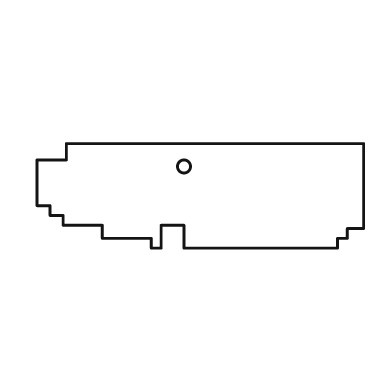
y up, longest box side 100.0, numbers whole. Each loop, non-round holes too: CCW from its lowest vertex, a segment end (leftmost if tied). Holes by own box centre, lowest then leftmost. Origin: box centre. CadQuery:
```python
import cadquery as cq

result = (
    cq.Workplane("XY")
    .moveTo(-15.0, -16.0)
    .lineTo(-12.0, -16.0)
    .lineTo(-12.0, -9.0)
    .lineTo(-5.0, -9.0)
    .lineTo(-5.0, -16.0)
    .lineTo(42.0, -16.0)
    .lineTo(42.0, -13.0)
    .lineTo(45.0, -13.0)
    .lineTo(45.0, -10.0)
    .lineTo(50.0, -10.0)
    .lineTo(50.0, 16.0)
    .lineTo(-41.0, 16.0)
    .lineTo(-41.0, 11.0)
    .lineTo(-50.0, 11.0)
    .lineTo(-50.0, -3.0)
    .lineTo(-46.0, -3.0)
    .lineTo(-46.0, -6.0)
    .lineTo(-42.0, -6.0)
    .lineTo(-42.0, -9.0)
    .lineTo(-30.0, -9.0)
    .lineTo(-30.0, -13.0)
    .lineTo(-15.0, -13.0)
    .close()
    .moveTo(-5.0, 9.0)
    .circle(2.0)
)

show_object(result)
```